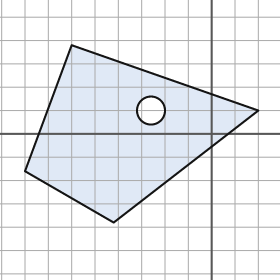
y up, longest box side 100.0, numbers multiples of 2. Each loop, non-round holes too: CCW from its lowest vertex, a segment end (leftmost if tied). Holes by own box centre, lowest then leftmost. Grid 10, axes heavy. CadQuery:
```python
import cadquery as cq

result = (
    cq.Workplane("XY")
    .moveTo(-42.0, -38.0)
    .lineTo(20.0, 10.0)
    .lineTo(-60.0, 38.0)
    .lineTo(-80.0, -16.0)
    .close()
    .moveTo(-26.0, 10.0)
    .circle(6.0)
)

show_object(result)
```